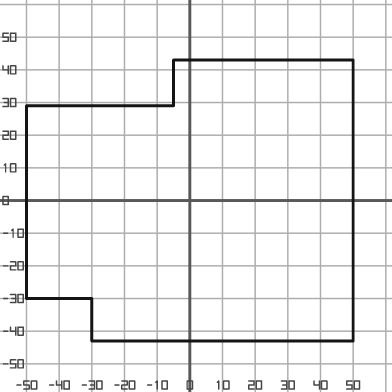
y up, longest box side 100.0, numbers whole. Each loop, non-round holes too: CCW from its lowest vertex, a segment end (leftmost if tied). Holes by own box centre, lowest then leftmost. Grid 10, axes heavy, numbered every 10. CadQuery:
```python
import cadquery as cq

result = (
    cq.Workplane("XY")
    .moveTo(-30.0, -43.0)
    .lineTo(50.0, -43.0)
    .lineTo(50.0, 43.0)
    .lineTo(-5.0, 43.0)
    .lineTo(-5.0, 29.0)
    .lineTo(-50.0, 29.0)
    .lineTo(-50.0, -30.0)
    .lineTo(-30.0, -30.0)
    .close()
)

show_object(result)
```